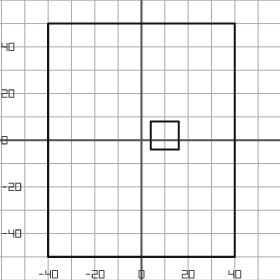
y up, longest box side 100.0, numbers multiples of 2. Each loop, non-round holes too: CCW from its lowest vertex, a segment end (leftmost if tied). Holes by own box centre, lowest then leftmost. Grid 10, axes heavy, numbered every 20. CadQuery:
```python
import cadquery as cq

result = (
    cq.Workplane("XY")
    .moveTo(-40.0, -50.0)
    .lineTo(40.0, -50.0)
    .lineTo(40.0, 50.0)
    .lineTo(-40.0, 50.0)
    .close()
    .moveTo(4.0, -4.0)
    .lineTo(16.0, -4.0)
    .lineTo(16.0, 8.0)
    .lineTo(4.0, 8.0)
    .close()
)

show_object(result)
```